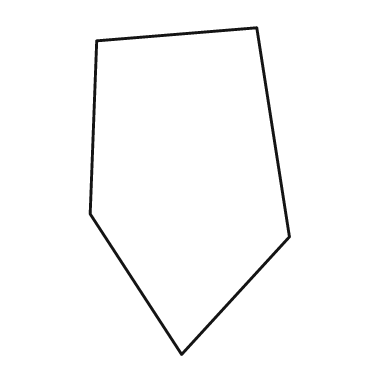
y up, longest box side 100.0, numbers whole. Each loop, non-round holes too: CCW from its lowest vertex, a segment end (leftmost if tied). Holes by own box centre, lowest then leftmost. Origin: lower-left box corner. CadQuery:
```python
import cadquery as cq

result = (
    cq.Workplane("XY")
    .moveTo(28.0, 0.0)
    .lineTo(61.0, 36.0)
    .lineTo(51.0, 100.0)
    .lineTo(2.0, 96.0)
    .lineTo(0.0, 43.0)
    .close()
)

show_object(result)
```